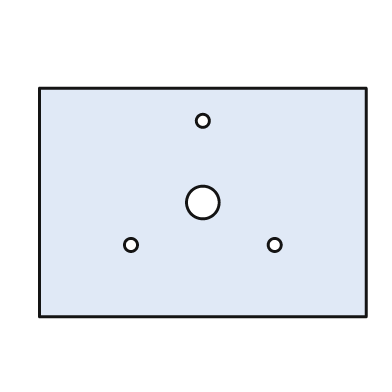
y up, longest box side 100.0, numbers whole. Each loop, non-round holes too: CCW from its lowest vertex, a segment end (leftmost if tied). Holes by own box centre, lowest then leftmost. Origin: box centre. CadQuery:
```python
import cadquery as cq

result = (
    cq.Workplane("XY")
    .moveTo(-50.0, -35.0)
    .lineTo(50.0, -35.0)
    .lineTo(50.0, 35.0)
    .lineTo(-50.0, 35.0)
    .close()
    .moveTo(-22.0, -13.0)
    .circle(2.0)
    .moveTo(22.0, -13.0)
    .circle(2.0)
    .moveTo(0.0, 0.0)
    .circle(5.0)
    .moveTo(0.0, 25.0)
    .circle(2.0)
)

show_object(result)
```